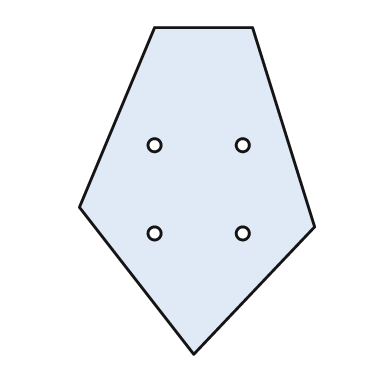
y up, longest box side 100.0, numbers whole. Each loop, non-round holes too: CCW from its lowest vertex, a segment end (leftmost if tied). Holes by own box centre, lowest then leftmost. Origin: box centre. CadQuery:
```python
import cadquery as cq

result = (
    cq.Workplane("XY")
    .moveTo(-1.0, -50.0)
    .lineTo(36.0, -11.0)
    .lineTo(17.0, 50.0)
    .lineTo(-13.0, 50.0)
    .lineTo(-36.0, -5.0)
    .close()
    .moveTo(-13.0, -13.0)
    .circle(2.0)
    .moveTo(14.0, -13.0)
    .circle(2.0)
    .moveTo(-13.0, 14.0)
    .circle(2.0)
    .moveTo(14.0, 14.0)
    .circle(2.0)
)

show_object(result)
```